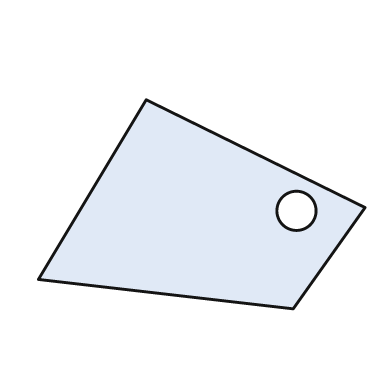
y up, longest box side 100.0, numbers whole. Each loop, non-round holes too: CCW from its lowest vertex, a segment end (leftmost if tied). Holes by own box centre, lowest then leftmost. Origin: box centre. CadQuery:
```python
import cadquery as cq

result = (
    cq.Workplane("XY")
    .moveTo(28.0, -32.0)
    .lineTo(50.0, -1.0)
    .lineTo(-17.0, 32.0)
    .lineTo(-50.0, -23.0)
    .close()
    .moveTo(29.0, -2.0)
    .circle(6.0)
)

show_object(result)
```